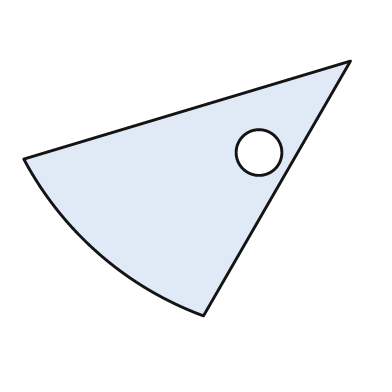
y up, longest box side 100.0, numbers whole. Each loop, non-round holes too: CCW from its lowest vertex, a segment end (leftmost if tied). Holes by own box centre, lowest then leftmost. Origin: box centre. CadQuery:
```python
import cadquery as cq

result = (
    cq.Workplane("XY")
    .moveTo(5.0, -39.0)
    .lineTo(50.0, 39.0)
    .lineTo(-50.0, 9.0)
    .threePointArc((-27.0, -20.0), (5.0, -39.0))
    .close()
    .moveTo(22.0, 11.0)
    .circle(7.0)
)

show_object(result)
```